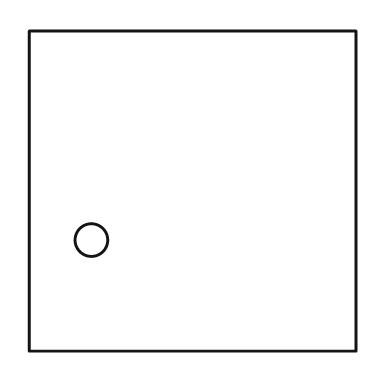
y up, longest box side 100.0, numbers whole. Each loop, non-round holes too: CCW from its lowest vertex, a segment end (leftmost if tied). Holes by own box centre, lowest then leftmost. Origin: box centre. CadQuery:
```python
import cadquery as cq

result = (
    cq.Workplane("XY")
    .moveTo(-50.0, -49.0)
    .lineTo(50.0, -49.0)
    .lineTo(50.0, 49.0)
    .lineTo(-50.0, 49.0)
    .close()
    .moveTo(-31.0, -15.0)
    .circle(5.0)
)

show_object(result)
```